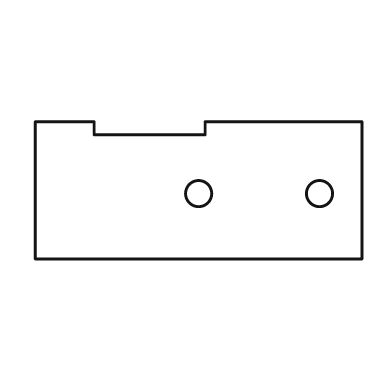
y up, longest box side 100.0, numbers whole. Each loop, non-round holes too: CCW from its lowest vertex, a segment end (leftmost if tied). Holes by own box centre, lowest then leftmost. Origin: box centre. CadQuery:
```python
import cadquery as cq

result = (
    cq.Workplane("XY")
    .moveTo(-50.0, -21.0)
    .lineTo(50.0, -21.0)
    .lineTo(50.0, 21.0)
    .lineTo(2.0, 21.0)
    .lineTo(2.0, 17.0)
    .lineTo(-32.0, 17.0)
    .lineTo(-32.0, 21.0)
    .lineTo(-50.0, 21.0)
    .close()
    .moveTo(0.0, -1.0)
    .circle(4.0)
    .moveTo(37.0, -1.0)
    .circle(4.0)
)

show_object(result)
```